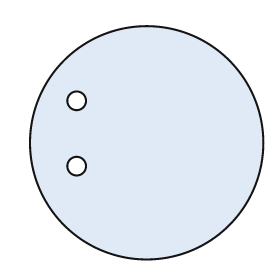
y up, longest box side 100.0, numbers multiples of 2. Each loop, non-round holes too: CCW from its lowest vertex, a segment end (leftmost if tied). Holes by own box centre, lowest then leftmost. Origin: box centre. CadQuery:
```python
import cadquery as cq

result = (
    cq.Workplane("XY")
    .moveTo(0.0, 0.0)
    .circle(50.0)
    .moveTo(-30.0, -10.0)
    .circle(4.0)
    .moveTo(-30.0, 18.0)
    .circle(4.0)
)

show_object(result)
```